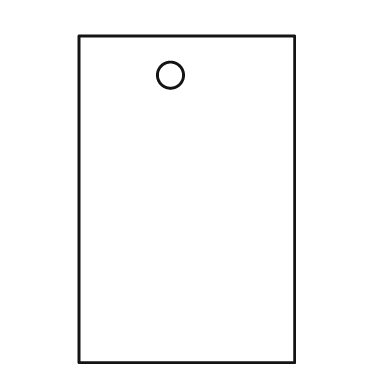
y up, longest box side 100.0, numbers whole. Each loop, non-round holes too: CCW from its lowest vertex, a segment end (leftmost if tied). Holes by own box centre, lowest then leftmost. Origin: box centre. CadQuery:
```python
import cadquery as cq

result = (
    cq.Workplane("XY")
    .moveTo(-33.0, -50.0)
    .lineTo(33.0, -50.0)
    .lineTo(33.0, 50.0)
    .lineTo(-33.0, 50.0)
    .close()
    .moveTo(-5.0, 38.0)
    .circle(4.0)
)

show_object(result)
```